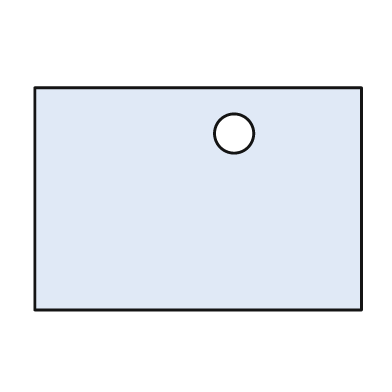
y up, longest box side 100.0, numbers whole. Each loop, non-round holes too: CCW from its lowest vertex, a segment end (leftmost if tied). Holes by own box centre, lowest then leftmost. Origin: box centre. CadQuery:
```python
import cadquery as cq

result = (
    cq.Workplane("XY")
    .moveTo(-50.0, -34.0)
    .lineTo(50.0, -34.0)
    .lineTo(50.0, 34.0)
    .lineTo(-50.0, 34.0)
    .close()
    .moveTo(11.0, 20.0)
    .circle(6.0)
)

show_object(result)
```